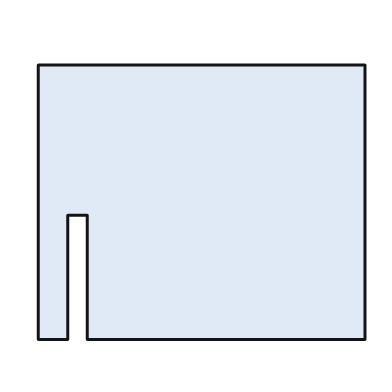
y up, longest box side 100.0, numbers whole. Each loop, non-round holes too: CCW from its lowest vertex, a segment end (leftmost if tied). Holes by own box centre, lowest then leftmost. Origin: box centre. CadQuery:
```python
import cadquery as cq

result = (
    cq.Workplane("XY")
    .moveTo(-50.0, -42.0)
    .lineTo(-41.0, -42.0)
    .lineTo(-41.0, -4.0)
    .lineTo(-35.0, -4.0)
    .lineTo(-35.0, -42.0)
    .lineTo(50.0, -42.0)
    .lineTo(50.0, 42.0)
    .lineTo(-50.0, 42.0)
    .close()
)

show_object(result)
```